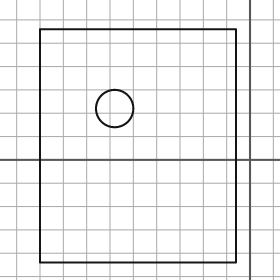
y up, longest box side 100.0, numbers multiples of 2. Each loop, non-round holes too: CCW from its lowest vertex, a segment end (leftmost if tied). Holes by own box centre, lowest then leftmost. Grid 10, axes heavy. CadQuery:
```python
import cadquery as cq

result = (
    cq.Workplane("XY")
    .moveTo(-90.0, -44.0)
    .lineTo(-6.0, -44.0)
    .lineTo(-6.0, 56.0)
    .lineTo(-90.0, 56.0)
    .close()
    .moveTo(-58.0, 22.0)
    .circle(8.0)
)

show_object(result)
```